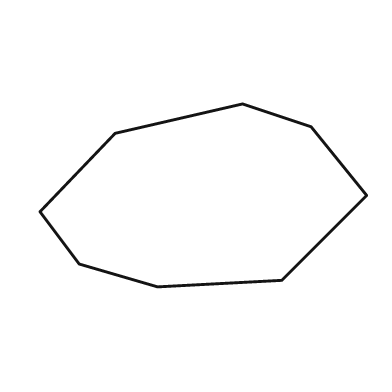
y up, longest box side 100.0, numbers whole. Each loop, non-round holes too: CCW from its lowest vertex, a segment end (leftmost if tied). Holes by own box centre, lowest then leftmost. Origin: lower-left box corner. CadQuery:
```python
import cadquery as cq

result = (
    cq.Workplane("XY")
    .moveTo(36.0, 0.0)
    .lineTo(74.0, 2.0)
    .lineTo(100.0, 28.0)
    .lineTo(83.0, 49.0)
    .lineTo(62.0, 56.0)
    .lineTo(23.0, 47.0)
    .lineTo(0.0, 23.0)
    .lineTo(12.0, 7.0)
    .close()
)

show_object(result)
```